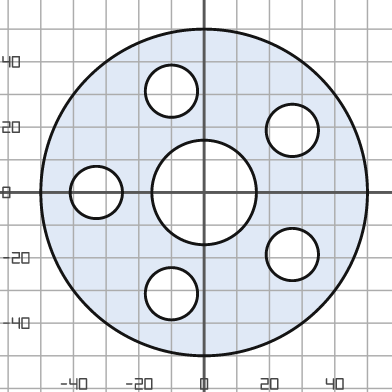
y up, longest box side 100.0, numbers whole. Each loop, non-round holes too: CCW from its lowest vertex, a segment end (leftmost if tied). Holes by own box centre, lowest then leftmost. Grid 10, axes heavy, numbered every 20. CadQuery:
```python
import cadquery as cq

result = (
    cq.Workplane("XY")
    .moveTo(0.0, 0.0)
    .circle(50.0)
    .moveTo(-10.0, -31.0)
    .circle(8.0)
    .moveTo(27.0, -19.0)
    .circle(8.0)
    .moveTo(-33.0, 0.0)
    .circle(8.0)
    .moveTo(0.0, 0.0)
    .circle(16.0)
    .moveTo(27.0, 19.0)
    .circle(8.0)
    .moveTo(-10.0, 31.0)
    .circle(8.0)
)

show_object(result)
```